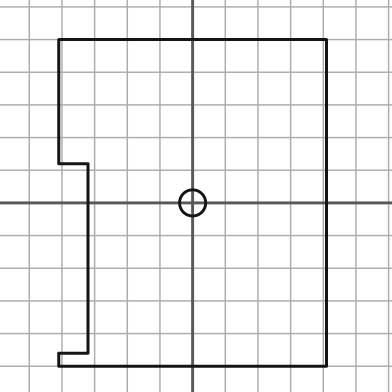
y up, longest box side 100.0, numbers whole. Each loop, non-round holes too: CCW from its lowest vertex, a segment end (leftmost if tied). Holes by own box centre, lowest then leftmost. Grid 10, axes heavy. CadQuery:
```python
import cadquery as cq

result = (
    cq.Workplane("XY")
    .moveTo(-41.0, -50.0)
    .lineTo(41.0, -50.0)
    .lineTo(41.0, 50.0)
    .lineTo(-41.0, 50.0)
    .lineTo(-41.0, 12.0)
    .lineTo(-32.0, 12.0)
    .lineTo(-32.0, -46.0)
    .lineTo(-41.0, -46.0)
    .close()
    .moveTo(0.0, 0.0)
    .circle(4.0)
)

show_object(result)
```